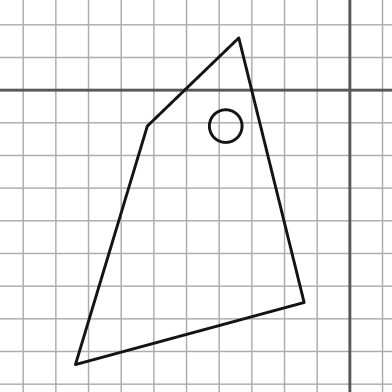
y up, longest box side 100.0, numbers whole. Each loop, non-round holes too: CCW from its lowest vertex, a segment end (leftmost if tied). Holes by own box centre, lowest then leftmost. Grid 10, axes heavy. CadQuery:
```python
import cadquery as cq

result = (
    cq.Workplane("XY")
    .moveTo(-84.0, -84.0)
    .lineTo(-14.0, -65.0)
    .lineTo(-34.0, 16.0)
    .lineTo(-62.0, -11.0)
    .close()
    .moveTo(-38.0, -11.0)
    .circle(5.0)
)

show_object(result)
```